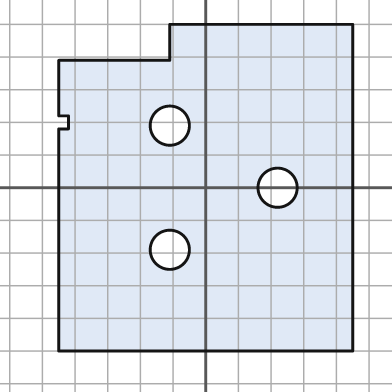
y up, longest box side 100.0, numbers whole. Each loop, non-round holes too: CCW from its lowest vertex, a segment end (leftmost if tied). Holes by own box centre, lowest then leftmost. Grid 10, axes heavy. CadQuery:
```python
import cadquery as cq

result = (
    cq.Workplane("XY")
    .moveTo(-45.0, -50.0)
    .lineTo(45.0, -50.0)
    .lineTo(45.0, 50.0)
    .lineTo(-11.0, 50.0)
    .lineTo(-11.0, 39.0)
    .lineTo(-45.0, 39.0)
    .lineTo(-45.0, 22.0)
    .lineTo(-42.0, 22.0)
    .lineTo(-42.0, 18.0)
    .lineTo(-45.0, 18.0)
    .close()
    .moveTo(-11.0, -19.0)
    .circle(6.0)
    .moveTo(22.0, 0.0)
    .circle(6.0)
    .moveTo(-11.0, 19.0)
    .circle(6.0)
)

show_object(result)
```